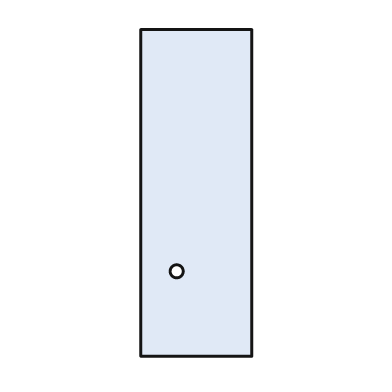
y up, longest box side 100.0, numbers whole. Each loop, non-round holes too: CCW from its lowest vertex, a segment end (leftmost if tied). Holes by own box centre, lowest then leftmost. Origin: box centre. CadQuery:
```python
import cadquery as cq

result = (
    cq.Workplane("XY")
    .moveTo(-17.0, -50.0)
    .lineTo(17.0, -50.0)
    .lineTo(17.0, 50.0)
    .lineTo(-17.0, 50.0)
    .close()
    .moveTo(-6.0, -24.0)
    .circle(2.0)
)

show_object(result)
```